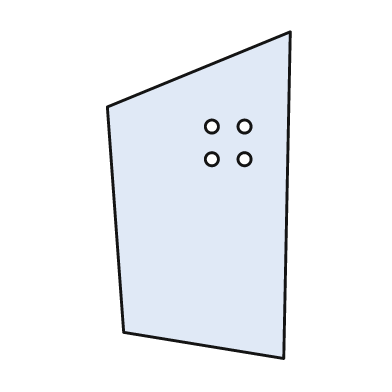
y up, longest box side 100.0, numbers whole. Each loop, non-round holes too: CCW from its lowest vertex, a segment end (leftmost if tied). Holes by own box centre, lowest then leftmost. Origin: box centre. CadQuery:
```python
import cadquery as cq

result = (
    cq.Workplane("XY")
    .moveTo(26.0, -50.0)
    .lineTo(28.0, 50.0)
    .lineTo(-28.0, 27.0)
    .lineTo(-23.0, -42.0)
    .close()
    .moveTo(4.0, 11.0)
    .circle(2.0)
    .moveTo(14.0, 11.0)
    .circle(2.0)
    .moveTo(4.0, 21.0)
    .circle(2.0)
    .moveTo(14.0, 21.0)
    .circle(2.0)
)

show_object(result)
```